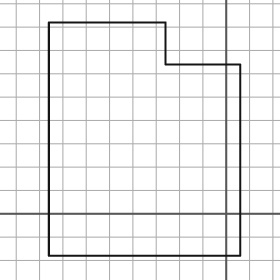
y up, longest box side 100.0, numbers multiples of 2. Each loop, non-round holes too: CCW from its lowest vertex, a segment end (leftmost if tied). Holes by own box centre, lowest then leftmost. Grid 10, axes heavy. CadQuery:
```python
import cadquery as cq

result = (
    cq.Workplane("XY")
    .moveTo(-76.0, -18.0)
    .lineTo(6.0, -18.0)
    .lineTo(6.0, 64.0)
    .lineTo(-26.0, 64.0)
    .lineTo(-26.0, 82.0)
    .lineTo(-76.0, 82.0)
    .close()
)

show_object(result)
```